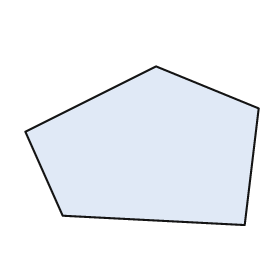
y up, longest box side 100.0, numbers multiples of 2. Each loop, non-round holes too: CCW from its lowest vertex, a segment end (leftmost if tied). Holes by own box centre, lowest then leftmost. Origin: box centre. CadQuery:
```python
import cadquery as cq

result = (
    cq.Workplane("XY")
    .moveTo(44.0, -34.0)
    .lineTo(50.0, 16.0)
    .lineTo(6.0, 34.0)
    .lineTo(-50.0, 6.0)
    .lineTo(-34.0, -30.0)
    .close()
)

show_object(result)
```